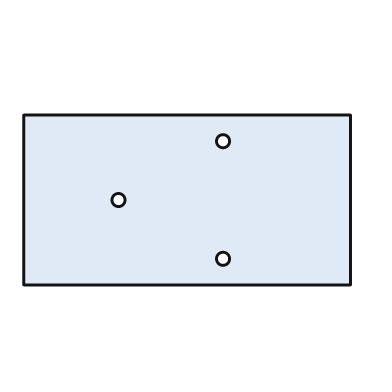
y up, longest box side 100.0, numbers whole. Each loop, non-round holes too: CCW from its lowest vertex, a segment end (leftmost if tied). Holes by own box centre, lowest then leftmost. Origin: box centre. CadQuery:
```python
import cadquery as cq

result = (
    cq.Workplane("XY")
    .moveTo(-50.0, -26.0)
    .lineTo(50.0, -26.0)
    .lineTo(50.0, 26.0)
    .lineTo(-50.0, 26.0)
    .close()
    .moveTo(11.0, -18.0)
    .circle(2.0)
    .moveTo(-21.0, 0.0)
    .circle(2.0)
    .moveTo(11.0, 18.0)
    .circle(2.0)
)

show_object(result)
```